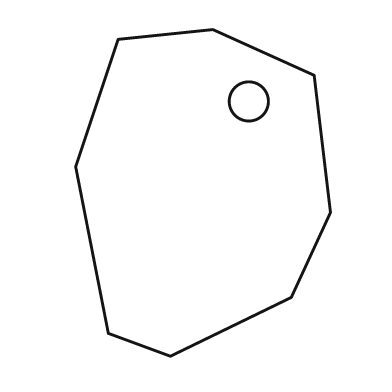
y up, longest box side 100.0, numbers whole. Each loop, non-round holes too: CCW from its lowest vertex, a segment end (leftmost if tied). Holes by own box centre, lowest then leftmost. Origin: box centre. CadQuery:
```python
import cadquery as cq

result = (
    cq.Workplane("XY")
    .moveTo(-10.0, -50.0)
    .lineTo(27.0, -32.0)
    .lineTo(39.0, -6.0)
    .lineTo(34.0, 36.0)
    .lineTo(3.0, 50.0)
    .lineTo(-26.0, 47.0)
    .lineTo(-39.0, 8.0)
    .lineTo(-29.0, -43.0)
    .close()
    .moveTo(14.0, 28.0)
    .circle(6.0)
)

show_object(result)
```